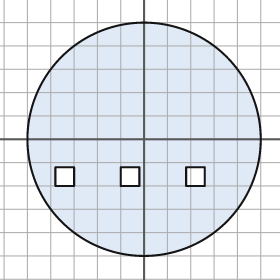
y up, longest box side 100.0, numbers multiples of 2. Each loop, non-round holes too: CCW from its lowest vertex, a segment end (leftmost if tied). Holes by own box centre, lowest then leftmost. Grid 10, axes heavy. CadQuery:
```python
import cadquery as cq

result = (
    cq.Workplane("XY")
    .moveTo(0.0, 0.0)
    .circle(50.0)
    .moveTo(-38.0, -20.0)
    .lineTo(-30.0, -20.0)
    .lineTo(-30.0, -12.0)
    .lineTo(-38.0, -12.0)
    .close()
    .moveTo(-10.0, -20.0)
    .lineTo(-2.0, -20.0)
    .lineTo(-2.0, -12.0)
    .lineTo(-10.0, -12.0)
    .close()
    .moveTo(18.0, -20.0)
    .lineTo(26.0, -20.0)
    .lineTo(26.0, -12.0)
    .lineTo(18.0, -12.0)
    .close()
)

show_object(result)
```